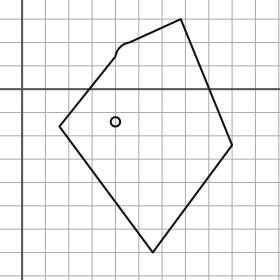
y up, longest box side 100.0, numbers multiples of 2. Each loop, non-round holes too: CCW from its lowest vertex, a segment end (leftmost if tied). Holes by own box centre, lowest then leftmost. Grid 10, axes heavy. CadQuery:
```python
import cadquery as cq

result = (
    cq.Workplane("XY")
    .moveTo(56.0, -70.0)
    .lineTo(90.0, -24.0)
    .lineTo(68.0, 30.0)
    .lineTo(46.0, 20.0)
    .threePointArc((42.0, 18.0), (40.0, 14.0))
    .lineTo(16.0, -16.0)
    .close()
    .moveTo(40.0, -14.0)
    .circle(2.0)
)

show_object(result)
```